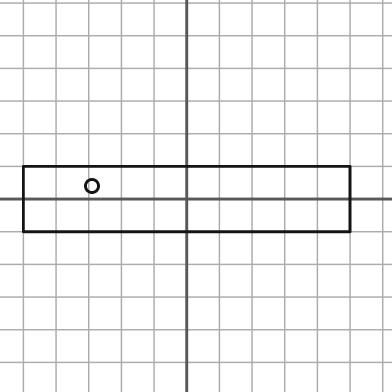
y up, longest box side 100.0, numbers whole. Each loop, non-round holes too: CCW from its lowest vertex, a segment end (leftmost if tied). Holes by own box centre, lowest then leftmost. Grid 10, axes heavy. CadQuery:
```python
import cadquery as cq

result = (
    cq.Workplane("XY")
    .moveTo(-50.0, -10.0)
    .lineTo(50.0, -10.0)
    .lineTo(50.0, 10.0)
    .lineTo(-50.0, 10.0)
    .close()
    .moveTo(-29.0, 4.0)
    .circle(2.0)
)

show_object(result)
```